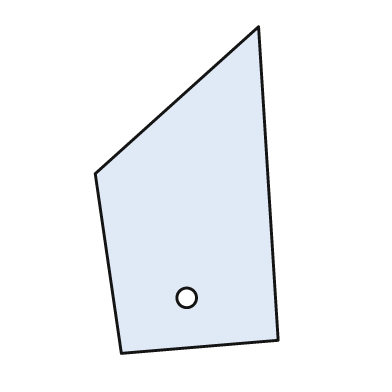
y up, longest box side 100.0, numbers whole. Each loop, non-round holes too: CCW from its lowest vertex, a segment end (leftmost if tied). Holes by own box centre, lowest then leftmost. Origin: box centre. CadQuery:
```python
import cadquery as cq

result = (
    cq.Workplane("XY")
    .moveTo(-20.0, -50.0)
    .lineTo(28.0, -46.0)
    .lineTo(22.0, 50.0)
    .lineTo(-28.0, 5.0)
    .close()
    .moveTo(0.0, -33.0)
    .circle(3.0)
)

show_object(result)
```